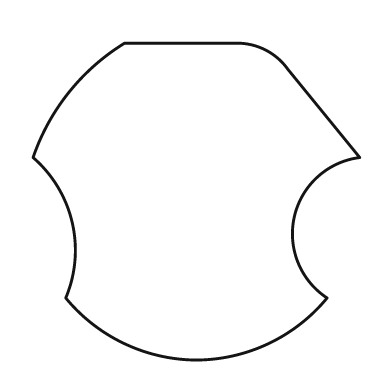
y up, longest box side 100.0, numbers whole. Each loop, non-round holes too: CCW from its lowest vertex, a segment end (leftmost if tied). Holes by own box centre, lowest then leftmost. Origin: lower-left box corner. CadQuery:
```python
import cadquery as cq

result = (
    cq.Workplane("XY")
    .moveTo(50.0, 0.0)
    .threePointArc((72.0, 5.0), (90.0, 19.0))
    .threePointArc((80.0, 44.0), (100.0, 62.0))
    .lineTo(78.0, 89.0)
    .threePointArc((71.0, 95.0), (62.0, 97.0))
    .lineTo(28.0, 97.0)
    .threePointArc((11.0, 82.0), (0.0, 62.0))
    .threePointArc((12.0, 42.0), (10.0, 19.0))
    .threePointArc((28.0, 5.0), (50.0, 0.0))
    .close()
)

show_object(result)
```